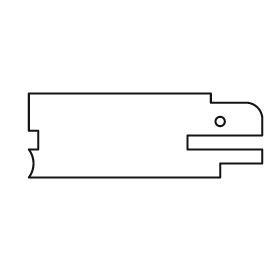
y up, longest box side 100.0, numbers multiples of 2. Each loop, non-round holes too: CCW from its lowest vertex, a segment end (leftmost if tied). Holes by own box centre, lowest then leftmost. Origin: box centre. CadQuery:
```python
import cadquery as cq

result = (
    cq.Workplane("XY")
    .moveTo(-50.0, -18.0)
    .lineTo(32.0, -18.0)
    .lineTo(32.0, -12.0)
    .lineTo(50.0, -12.0)
    .lineTo(50.0, -6.0)
    .lineTo(18.0, -6.0)
    .lineTo(18.0, 0.0)
    .lineTo(50.0, 0.0)
    .lineTo(50.0, 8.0)
    .threePointArc((48.0, 12.0), (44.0, 14.0))
    .lineTo(28.0, 14.0)
    .lineTo(28.0, 18.0)
    .lineTo(-50.0, 18.0)
    .lineTo(-50.0, 2.0)
    .lineTo(-46.0, 2.0)
    .lineTo(-46.0, -6.0)
    .lineTo(-50.0, -6.0)
    .threePointArc((-48.0, -12.0), (-50.0, -18.0))
    .close()
    .moveTo(32.0, 6.0)
    .circle(2.0)
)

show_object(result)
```